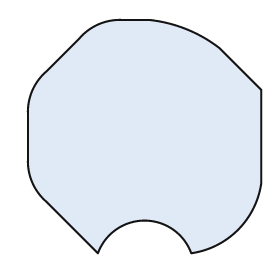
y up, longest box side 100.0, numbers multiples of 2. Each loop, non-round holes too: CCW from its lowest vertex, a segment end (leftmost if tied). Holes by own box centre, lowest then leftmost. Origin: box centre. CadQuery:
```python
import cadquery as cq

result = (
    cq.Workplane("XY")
    .moveTo(-20.0, -50.0)
    .threePointArc((0.0, -36.0), (20.0, -50.0))
    .threePointArc((40.0, -40.0), (50.0, -20.0))
    .lineTo(50.0, 20.0)
    .lineTo(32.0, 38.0)
    .threePointArc((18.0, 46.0), (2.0, 50.0))
    .lineTo(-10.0, 50.0)
    .threePointArc((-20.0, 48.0), (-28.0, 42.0))
    .lineTo(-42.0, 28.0)
    .threePointArc((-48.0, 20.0), (-50.0, 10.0))
    .lineTo(-50.0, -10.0)
    .threePointArc((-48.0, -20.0), (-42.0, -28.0))
    .close()
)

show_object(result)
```